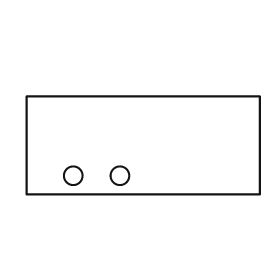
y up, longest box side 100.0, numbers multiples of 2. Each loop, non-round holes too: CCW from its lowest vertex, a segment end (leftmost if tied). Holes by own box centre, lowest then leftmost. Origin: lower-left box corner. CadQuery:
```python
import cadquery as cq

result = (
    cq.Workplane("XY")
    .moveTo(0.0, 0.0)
    .lineTo(100.0, 0.0)
    .lineTo(100.0, 42.0)
    .lineTo(0.0, 42.0)
    .close()
    .moveTo(20.0, 8.0)
    .circle(4.0)
    .moveTo(40.0, 8.0)
    .circle(4.0)
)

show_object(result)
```